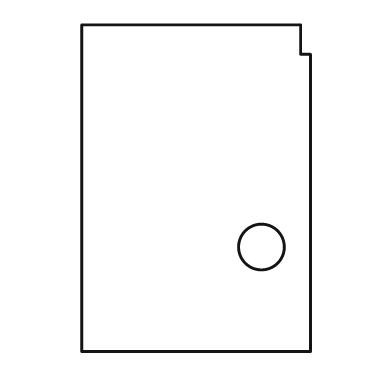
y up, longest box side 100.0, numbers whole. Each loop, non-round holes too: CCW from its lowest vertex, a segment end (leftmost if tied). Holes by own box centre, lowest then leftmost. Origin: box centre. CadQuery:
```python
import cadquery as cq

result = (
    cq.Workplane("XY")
    .moveTo(-35.0, -50.0)
    .lineTo(35.0, -50.0)
    .lineTo(35.0, 41.0)
    .lineTo(32.0, 41.0)
    .lineTo(32.0, 50.0)
    .lineTo(-35.0, 50.0)
    .close()
    .moveTo(20.0, -18.0)
    .circle(7.0)
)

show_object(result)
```